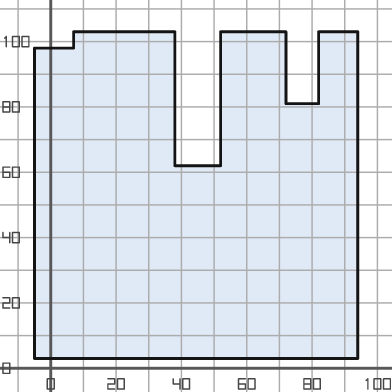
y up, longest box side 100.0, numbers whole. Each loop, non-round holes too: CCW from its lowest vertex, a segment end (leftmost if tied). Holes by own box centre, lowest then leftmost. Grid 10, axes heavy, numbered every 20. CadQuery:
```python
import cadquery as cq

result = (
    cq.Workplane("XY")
    .moveTo(-5.0, 3.0)
    .lineTo(94.0, 3.0)
    .lineTo(94.0, 103.0)
    .lineTo(82.0, 103.0)
    .lineTo(82.0, 81.0)
    .lineTo(72.0, 81.0)
    .lineTo(72.0, 103.0)
    .lineTo(52.0, 103.0)
    .lineTo(52.0, 62.0)
    .lineTo(38.0, 62.0)
    .lineTo(38.0, 103.0)
    .lineTo(7.0, 103.0)
    .lineTo(7.0, 98.0)
    .lineTo(-5.0, 98.0)
    .close()
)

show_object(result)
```